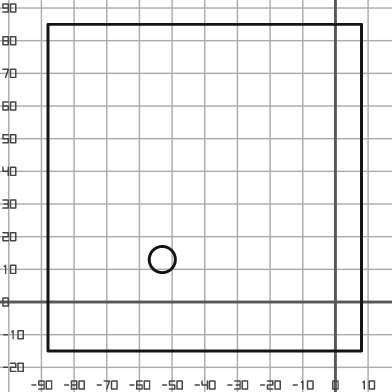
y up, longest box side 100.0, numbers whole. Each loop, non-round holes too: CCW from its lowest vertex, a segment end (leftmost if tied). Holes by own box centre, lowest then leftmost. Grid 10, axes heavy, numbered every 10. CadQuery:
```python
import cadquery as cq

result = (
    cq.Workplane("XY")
    .moveTo(-88.0, -15.0)
    .lineTo(8.0, -15.0)
    .lineTo(8.0, 85.0)
    .lineTo(-88.0, 85.0)
    .close()
    .moveTo(-53.0, 13.0)
    .circle(4.0)
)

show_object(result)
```